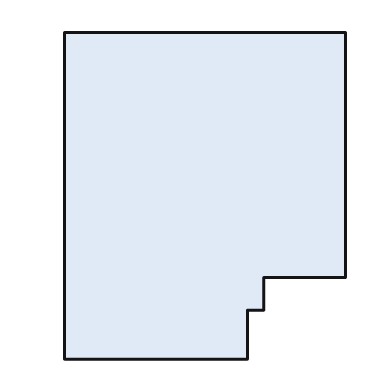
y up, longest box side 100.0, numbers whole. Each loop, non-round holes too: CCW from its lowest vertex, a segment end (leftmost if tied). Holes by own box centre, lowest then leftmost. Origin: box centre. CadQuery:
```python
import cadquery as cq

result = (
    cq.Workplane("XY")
    .moveTo(-43.0, -50.0)
    .lineTo(13.0, -50.0)
    .lineTo(13.0, -35.0)
    .lineTo(18.0, -35.0)
    .lineTo(18.0, -25.0)
    .lineTo(43.0, -25.0)
    .lineTo(43.0, 50.0)
    .lineTo(-43.0, 50.0)
    .close()
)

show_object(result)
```